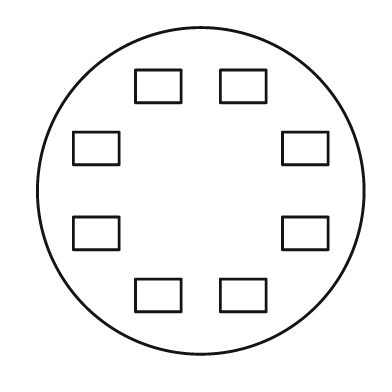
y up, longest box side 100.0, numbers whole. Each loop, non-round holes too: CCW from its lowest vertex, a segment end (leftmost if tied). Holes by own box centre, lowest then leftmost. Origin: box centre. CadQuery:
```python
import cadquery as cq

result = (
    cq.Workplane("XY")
    .moveTo(0.0, 0.0)
    .circle(50.0)
    .moveTo(-20.0, -37.0)
    .lineTo(-6.0, -37.0)
    .lineTo(-6.0, -27.0)
    .lineTo(-20.0, -27.0)
    .close()
    .moveTo(6.0, -37.0)
    .lineTo(20.0, -37.0)
    .lineTo(20.0, -27.0)
    .lineTo(6.0, -27.0)
    .close()
    .moveTo(-39.0, -18.0)
    .lineTo(-25.0, -18.0)
    .lineTo(-25.0, -8.0)
    .lineTo(-39.0, -8.0)
    .close()
    .moveTo(25.0, -18.0)
    .lineTo(39.0, -18.0)
    .lineTo(39.0, -8.0)
    .lineTo(25.0, -8.0)
    .close()
    .moveTo(-39.0, 8.0)
    .lineTo(-25.0, 8.0)
    .lineTo(-25.0, 18.0)
    .lineTo(-39.0, 18.0)
    .close()
    .moveTo(25.0, 8.0)
    .lineTo(39.0, 8.0)
    .lineTo(39.0, 18.0)
    .lineTo(25.0, 18.0)
    .close()
    .moveTo(-20.0, 27.0)
    .lineTo(-6.0, 27.0)
    .lineTo(-6.0, 37.0)
    .lineTo(-20.0, 37.0)
    .close()
    .moveTo(6.0, 27.0)
    .lineTo(20.0, 27.0)
    .lineTo(20.0, 37.0)
    .lineTo(6.0, 37.0)
    .close()
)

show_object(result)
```